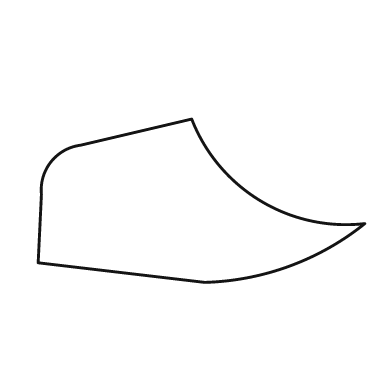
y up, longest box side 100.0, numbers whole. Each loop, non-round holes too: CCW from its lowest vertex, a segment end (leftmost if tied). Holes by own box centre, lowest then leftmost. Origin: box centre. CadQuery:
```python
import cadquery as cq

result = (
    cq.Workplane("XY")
    .moveTo(1.0, -25.0)
    .threePointArc((27.0, -20.0), (50.0, -7.0))
    .threePointArc((18.0, 0.0), (-3.0, 25.0))
    .lineTo(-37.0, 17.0)
    .threePointArc((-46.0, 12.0), (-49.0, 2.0))
    .lineTo(-50.0, -19.0)
    .close()
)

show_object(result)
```